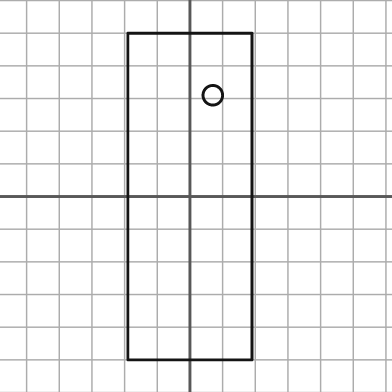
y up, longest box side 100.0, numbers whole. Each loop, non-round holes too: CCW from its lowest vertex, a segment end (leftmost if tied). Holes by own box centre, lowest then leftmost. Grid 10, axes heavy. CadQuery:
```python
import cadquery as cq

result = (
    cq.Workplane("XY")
    .moveTo(-19.0, -50.0)
    .lineTo(19.0, -50.0)
    .lineTo(19.0, 50.0)
    .lineTo(-19.0, 50.0)
    .close()
    .moveTo(7.0, 31.0)
    .circle(3.0)
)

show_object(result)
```